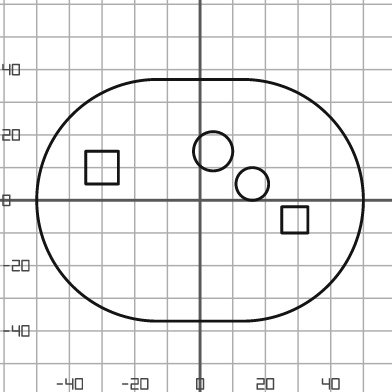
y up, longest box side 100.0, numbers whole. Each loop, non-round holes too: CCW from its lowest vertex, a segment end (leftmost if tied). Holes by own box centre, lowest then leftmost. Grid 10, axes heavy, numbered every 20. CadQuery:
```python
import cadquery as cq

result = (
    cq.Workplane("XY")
    .moveTo(-13.0, -37.0)
    .lineTo(13.0, -37.0)
    .threePointArc((50.0, 0.0), (13.0, 37.0))
    .lineTo(-13.0, 37.0)
    .threePointArc((-50.0, 0.0), (-13.0, -37.0))
    .close()
    .moveTo(25.0, -10.0)
    .lineTo(33.0, -10.0)
    .lineTo(33.0, -2.0)
    .lineTo(25.0, -2.0)
    .close()
    .moveTo(16.0, 5.0)
    .circle(5.0)
    .moveTo(-35.0, 5.0)
    .lineTo(-25.0, 5.0)
    .lineTo(-25.0, 15.0)
    .lineTo(-35.0, 15.0)
    .close()
    .moveTo(4.0, 15.0)
    .circle(6.0)
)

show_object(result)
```